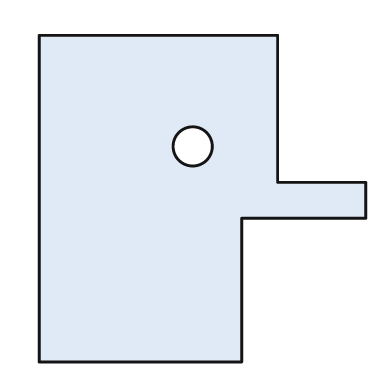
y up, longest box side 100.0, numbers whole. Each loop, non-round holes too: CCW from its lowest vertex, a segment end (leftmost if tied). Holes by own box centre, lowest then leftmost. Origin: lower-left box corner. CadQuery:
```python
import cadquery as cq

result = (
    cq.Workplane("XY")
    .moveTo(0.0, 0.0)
    .lineTo(62.0, 0.0)
    .lineTo(62.0, 44.0)
    .lineTo(100.0, 44.0)
    .lineTo(100.0, 55.0)
    .lineTo(73.0, 55.0)
    .lineTo(73.0, 100.0)
    .lineTo(0.0, 100.0)
    .close()
    .moveTo(47.0, 66.0)
    .circle(6.0)
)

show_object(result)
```